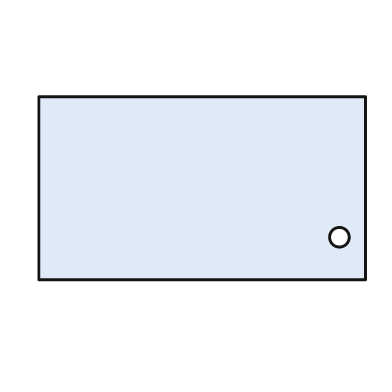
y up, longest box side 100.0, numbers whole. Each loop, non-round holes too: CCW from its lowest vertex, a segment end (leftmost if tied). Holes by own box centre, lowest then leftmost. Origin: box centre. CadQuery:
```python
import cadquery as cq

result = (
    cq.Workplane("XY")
    .moveTo(-50.0, -28.0)
    .lineTo(50.0, -28.0)
    .lineTo(50.0, 28.0)
    .lineTo(-50.0, 28.0)
    .close()
    .moveTo(42.0, -15.0)
    .circle(3.0)
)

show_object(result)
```